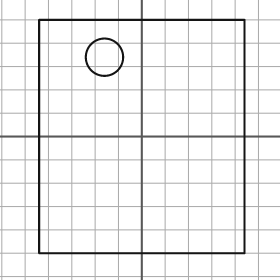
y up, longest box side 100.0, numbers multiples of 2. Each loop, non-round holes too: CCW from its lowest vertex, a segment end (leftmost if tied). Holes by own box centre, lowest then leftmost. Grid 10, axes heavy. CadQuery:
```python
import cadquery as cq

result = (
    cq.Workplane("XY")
    .moveTo(-44.0, -50.0)
    .lineTo(44.0, -50.0)
    .lineTo(44.0, 50.0)
    .lineTo(-44.0, 50.0)
    .close()
    .moveTo(-16.0, 34.0)
    .circle(8.0)
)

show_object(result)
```